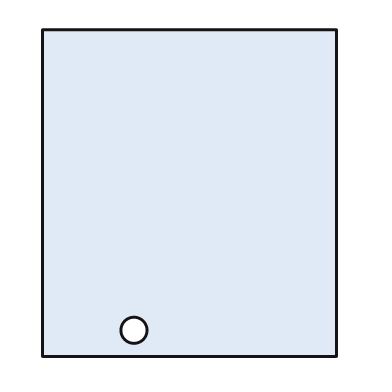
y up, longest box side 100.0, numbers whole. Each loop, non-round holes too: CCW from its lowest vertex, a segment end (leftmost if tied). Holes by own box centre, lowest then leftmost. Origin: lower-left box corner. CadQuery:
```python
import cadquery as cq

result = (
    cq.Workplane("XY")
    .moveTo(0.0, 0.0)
    .lineTo(90.0, 0.0)
    .lineTo(90.0, 100.0)
    .lineTo(0.0, 100.0)
    .close()
    .moveTo(28.0, 8.0)
    .circle(4.0)
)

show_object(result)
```